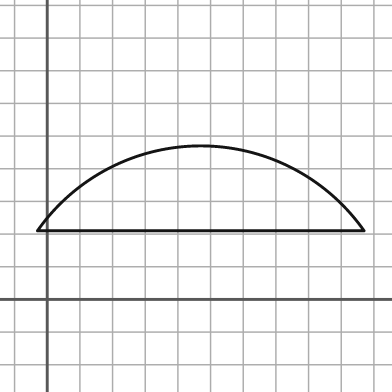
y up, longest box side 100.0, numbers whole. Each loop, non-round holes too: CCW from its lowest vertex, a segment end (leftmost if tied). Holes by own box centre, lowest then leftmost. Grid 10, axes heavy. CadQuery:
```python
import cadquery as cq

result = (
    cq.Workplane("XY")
    .moveTo(-3.0, 21.0)
    .lineTo(97.0, 21.0)
    .threePointArc((47.0, 47.0), (-3.0, 21.0))
    .close()
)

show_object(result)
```